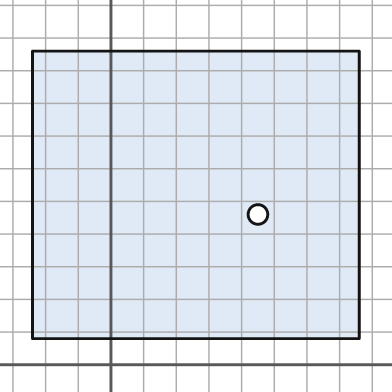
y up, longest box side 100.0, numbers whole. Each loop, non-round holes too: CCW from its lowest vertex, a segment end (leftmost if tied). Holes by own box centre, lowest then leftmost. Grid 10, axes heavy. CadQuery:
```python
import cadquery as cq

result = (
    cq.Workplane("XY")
    .moveTo(-24.0, 8.0)
    .lineTo(76.0, 8.0)
    .lineTo(76.0, 96.0)
    .lineTo(-24.0, 96.0)
    .close()
    .moveTo(45.0, 46.0)
    .circle(3.0)
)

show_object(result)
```